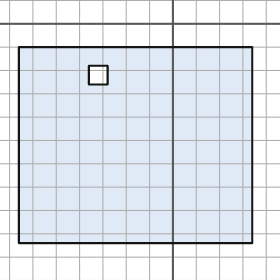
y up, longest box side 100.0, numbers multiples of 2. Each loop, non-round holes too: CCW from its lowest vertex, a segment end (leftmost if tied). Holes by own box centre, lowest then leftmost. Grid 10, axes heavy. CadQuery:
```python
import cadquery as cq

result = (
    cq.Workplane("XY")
    .moveTo(-66.0, -94.0)
    .lineTo(34.0, -94.0)
    .lineTo(34.0, -10.0)
    .lineTo(-66.0, -10.0)
    .close()
    .moveTo(-36.0, -26.0)
    .lineTo(-28.0, -26.0)
    .lineTo(-28.0, -18.0)
    .lineTo(-36.0, -18.0)
    .close()
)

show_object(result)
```